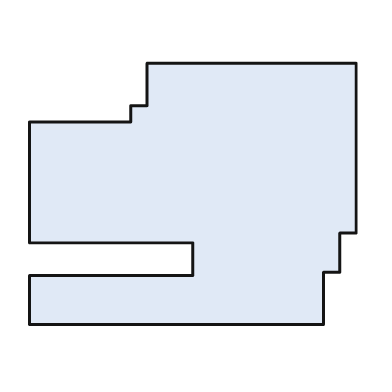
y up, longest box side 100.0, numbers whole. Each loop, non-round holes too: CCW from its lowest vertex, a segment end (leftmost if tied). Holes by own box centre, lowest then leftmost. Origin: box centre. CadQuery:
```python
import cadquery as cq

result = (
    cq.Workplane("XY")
    .moveTo(-50.0, -40.0)
    .lineTo(40.0, -40.0)
    .lineTo(40.0, -24.0)
    .lineTo(45.0, -24.0)
    .lineTo(45.0, -12.0)
    .lineTo(50.0, -12.0)
    .lineTo(50.0, 40.0)
    .lineTo(-14.0, 40.0)
    .lineTo(-14.0, 27.0)
    .lineTo(-19.0, 27.0)
    .lineTo(-19.0, 22.0)
    .lineTo(-50.0, 22.0)
    .lineTo(-50.0, -15.0)
    .lineTo(0.0, -15.0)
    .lineTo(0.0, -25.0)
    .lineTo(-50.0, -25.0)
    .close()
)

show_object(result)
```